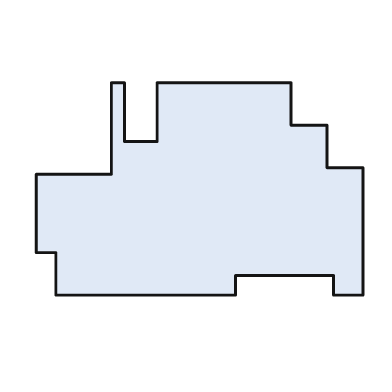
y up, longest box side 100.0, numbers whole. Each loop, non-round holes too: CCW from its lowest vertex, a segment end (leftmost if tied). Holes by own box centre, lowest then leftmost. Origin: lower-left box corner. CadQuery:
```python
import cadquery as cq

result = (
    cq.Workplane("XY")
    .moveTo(6.0, 0.0)
    .lineTo(61.0, 0.0)
    .lineTo(61.0, 6.0)
    .lineTo(91.0, 6.0)
    .lineTo(91.0, 0.0)
    .lineTo(100.0, 0.0)
    .lineTo(100.0, 39.0)
    .lineTo(89.0, 39.0)
    .lineTo(89.0, 52.0)
    .lineTo(78.0, 52.0)
    .lineTo(78.0, 65.0)
    .lineTo(37.0, 65.0)
    .lineTo(37.0, 47.0)
    .lineTo(27.0, 47.0)
    .lineTo(27.0, 65.0)
    .lineTo(23.0, 65.0)
    .lineTo(23.0, 37.0)
    .lineTo(0.0, 37.0)
    .lineTo(0.0, 13.0)
    .lineTo(6.0, 13.0)
    .close()
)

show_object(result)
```